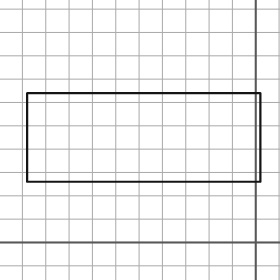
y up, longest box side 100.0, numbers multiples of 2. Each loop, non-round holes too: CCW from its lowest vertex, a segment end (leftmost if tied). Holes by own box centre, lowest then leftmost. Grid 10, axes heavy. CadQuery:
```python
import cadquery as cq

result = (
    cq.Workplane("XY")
    .moveTo(-98.0, 26.0)
    .lineTo(2.0, 26.0)
    .lineTo(2.0, 64.0)
    .lineTo(-98.0, 64.0)
    .close()
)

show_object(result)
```